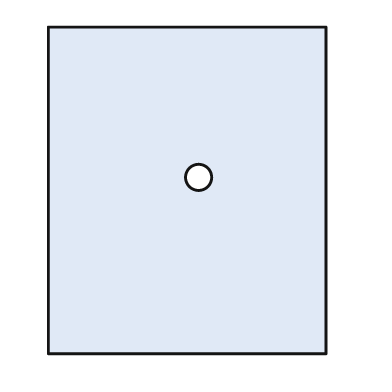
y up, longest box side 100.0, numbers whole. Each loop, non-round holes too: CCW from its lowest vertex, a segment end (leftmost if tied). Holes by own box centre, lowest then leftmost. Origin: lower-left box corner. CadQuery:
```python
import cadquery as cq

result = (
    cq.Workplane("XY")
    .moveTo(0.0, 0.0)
    .lineTo(85.0, 0.0)
    .lineTo(85.0, 100.0)
    .lineTo(0.0, 100.0)
    .close()
    .moveTo(46.0, 54.0)
    .circle(4.0)
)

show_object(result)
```